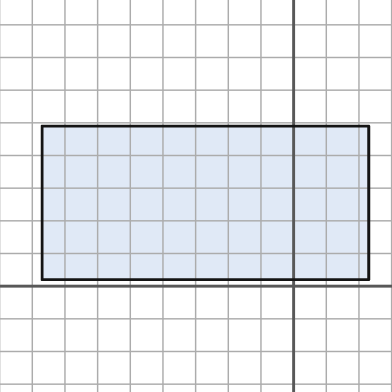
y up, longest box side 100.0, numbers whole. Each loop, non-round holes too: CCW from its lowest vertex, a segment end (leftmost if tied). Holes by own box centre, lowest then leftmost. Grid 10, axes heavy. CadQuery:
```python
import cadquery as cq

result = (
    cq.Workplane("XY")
    .moveTo(-77.0, 2.0)
    .lineTo(23.0, 2.0)
    .lineTo(23.0, 49.0)
    .lineTo(-77.0, 49.0)
    .close()
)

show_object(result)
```